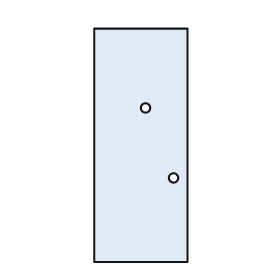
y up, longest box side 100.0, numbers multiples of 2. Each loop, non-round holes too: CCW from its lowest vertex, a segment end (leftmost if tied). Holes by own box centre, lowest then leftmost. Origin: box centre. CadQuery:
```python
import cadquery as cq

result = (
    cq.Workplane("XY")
    .moveTo(-20.0, -50.0)
    .lineTo(20.0, -50.0)
    .lineTo(20.0, 50.0)
    .lineTo(-20.0, 50.0)
    .close()
    .moveTo(14.0, -14.0)
    .circle(2.0)
    .moveTo(2.0, 16.0)
    .circle(2.0)
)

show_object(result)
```